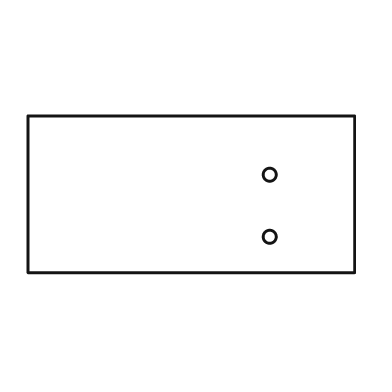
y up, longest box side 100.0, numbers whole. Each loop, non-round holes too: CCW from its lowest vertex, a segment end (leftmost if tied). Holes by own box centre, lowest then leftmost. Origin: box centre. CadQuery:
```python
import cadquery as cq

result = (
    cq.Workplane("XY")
    .moveTo(-50.0, -24.0)
    .lineTo(50.0, -24.0)
    .lineTo(50.0, 24.0)
    .lineTo(-50.0, 24.0)
    .close()
    .moveTo(24.0, -13.0)
    .circle(2.0)
    .moveTo(24.0, 6.0)
    .circle(2.0)
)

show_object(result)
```